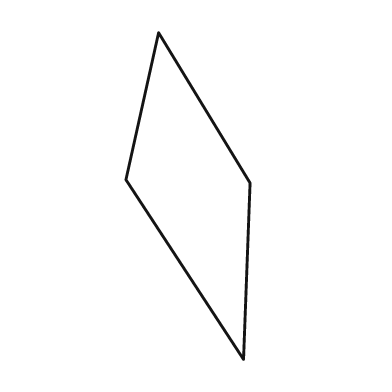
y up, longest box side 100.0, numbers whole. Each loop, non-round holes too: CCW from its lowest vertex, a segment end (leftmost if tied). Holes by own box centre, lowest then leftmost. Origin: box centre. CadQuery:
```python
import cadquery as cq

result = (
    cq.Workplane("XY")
    .moveTo(17.0, -50.0)
    .lineTo(19.0, 4.0)
    .lineTo(-9.0, 50.0)
    .lineTo(-19.0, 5.0)
    .close()
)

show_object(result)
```